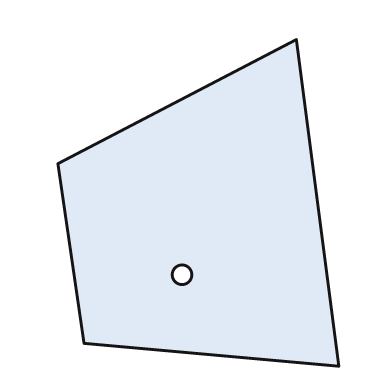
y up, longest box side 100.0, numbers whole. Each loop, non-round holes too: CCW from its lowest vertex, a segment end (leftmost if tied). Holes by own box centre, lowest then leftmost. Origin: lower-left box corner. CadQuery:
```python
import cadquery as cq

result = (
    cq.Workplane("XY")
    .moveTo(86.0, 0.0)
    .lineTo(73.0, 100.0)
    .lineTo(0.0, 62.0)
    .lineTo(8.0, 7.0)
    .close()
    .moveTo(38.0, 28.0)
    .circle(3.0)
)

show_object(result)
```